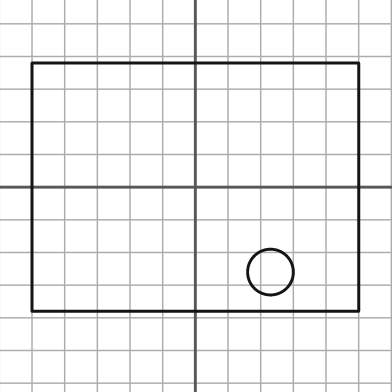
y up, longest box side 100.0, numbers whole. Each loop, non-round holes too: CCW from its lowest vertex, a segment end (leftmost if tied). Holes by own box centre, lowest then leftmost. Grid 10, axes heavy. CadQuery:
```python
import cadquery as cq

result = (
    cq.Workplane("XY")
    .moveTo(-50.0, -38.0)
    .lineTo(50.0, -38.0)
    .lineTo(50.0, 38.0)
    .lineTo(-50.0, 38.0)
    .close()
    .moveTo(23.0, -26.0)
    .circle(7.0)
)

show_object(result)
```